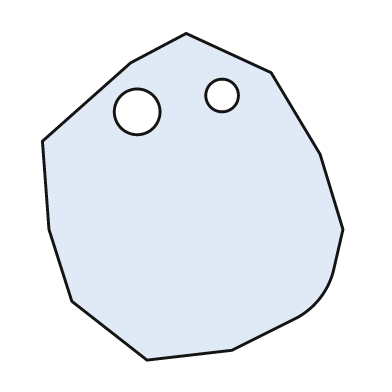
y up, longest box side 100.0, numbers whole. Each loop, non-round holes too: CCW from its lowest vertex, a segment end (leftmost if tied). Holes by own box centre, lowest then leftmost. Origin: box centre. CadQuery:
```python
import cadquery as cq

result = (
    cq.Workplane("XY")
    .moveTo(-14.0, -50.0)
    .lineTo(12.0, -47.0)
    .lineTo(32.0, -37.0)
    .threePointArc((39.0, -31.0), (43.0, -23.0))
    .lineTo(46.0, -10.0)
    .lineTo(39.0, 13.0)
    .lineTo(24.0, 38.0)
    .lineTo(-2.0, 50.0)
    .lineTo(-19.0, 41.0)
    .lineTo(-46.0, 17.0)
    .lineTo(-44.0, -10.0)
    .lineTo(-37.0, -32.0)
    .close()
    .moveTo(-17.0, 26.0)
    .circle(7.0)
    .moveTo(9.0, 31.0)
    .circle(5.0)
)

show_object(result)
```